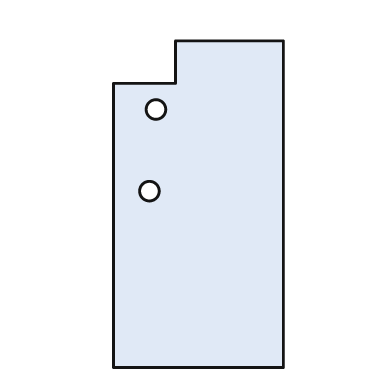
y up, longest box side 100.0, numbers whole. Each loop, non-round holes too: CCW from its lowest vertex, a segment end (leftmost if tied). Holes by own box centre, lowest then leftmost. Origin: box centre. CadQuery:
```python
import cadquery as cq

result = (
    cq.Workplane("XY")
    .moveTo(-26.0, -50.0)
    .lineTo(26.0, -50.0)
    .lineTo(26.0, 50.0)
    .lineTo(-7.0, 50.0)
    .lineTo(-7.0, 37.0)
    .lineTo(-26.0, 37.0)
    .close()
    .moveTo(-15.0, 4.0)
    .circle(3.0)
    .moveTo(-13.0, 29.0)
    .circle(3.0)
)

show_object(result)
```